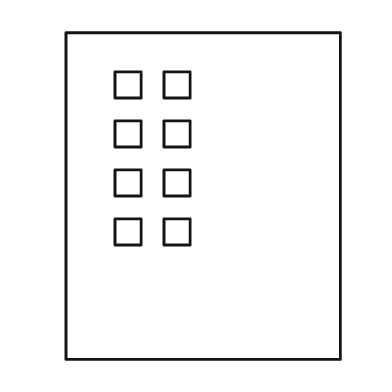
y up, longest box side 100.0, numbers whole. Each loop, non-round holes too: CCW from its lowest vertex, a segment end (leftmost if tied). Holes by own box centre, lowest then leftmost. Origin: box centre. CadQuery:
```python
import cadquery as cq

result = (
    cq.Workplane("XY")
    .moveTo(-42.0, -50.0)
    .lineTo(42.0, -50.0)
    .lineTo(42.0, 50.0)
    .lineTo(-42.0, 50.0)
    .close()
    .moveTo(-27.0, -15.0)
    .lineTo(-19.0, -15.0)
    .lineTo(-19.0, -7.0)
    .lineTo(-27.0, -7.0)
    .close()
    .moveTo(-12.0, -15.0)
    .lineTo(-4.0, -15.0)
    .lineTo(-4.0, -7.0)
    .lineTo(-12.0, -7.0)
    .close()
    .moveTo(-27.0, 0.0)
    .lineTo(-19.0, 0.0)
    .lineTo(-19.0, 8.0)
    .lineTo(-27.0, 8.0)
    .close()
    .moveTo(-12.0, 0.0)
    .lineTo(-4.0, 0.0)
    .lineTo(-4.0, 8.0)
    .lineTo(-12.0, 8.0)
    .close()
    .moveTo(-27.0, 15.0)
    .lineTo(-19.0, 15.0)
    .lineTo(-19.0, 23.0)
    .lineTo(-27.0, 23.0)
    .close()
    .moveTo(-12.0, 15.0)
    .lineTo(-4.0, 15.0)
    .lineTo(-4.0, 23.0)
    .lineTo(-12.0, 23.0)
    .close()
    .moveTo(-27.0, 30.0)
    .lineTo(-19.0, 30.0)
    .lineTo(-19.0, 38.0)
    .lineTo(-27.0, 38.0)
    .close()
    .moveTo(-12.0, 30.0)
    .lineTo(-4.0, 30.0)
    .lineTo(-4.0, 38.0)
    .lineTo(-12.0, 38.0)
    .close()
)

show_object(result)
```